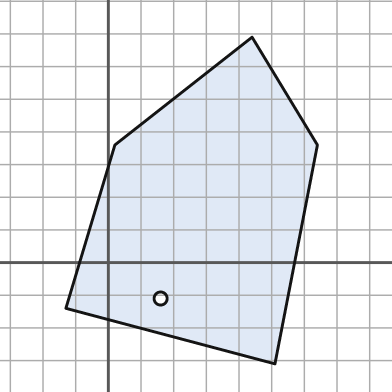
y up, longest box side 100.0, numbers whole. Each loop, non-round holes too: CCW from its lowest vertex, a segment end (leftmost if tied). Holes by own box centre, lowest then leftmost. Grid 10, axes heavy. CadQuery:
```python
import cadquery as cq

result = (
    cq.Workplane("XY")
    .moveTo(51.0, -31.0)
    .lineTo(64.0, 36.0)
    .lineTo(44.0, 69.0)
    .lineTo(2.0, 36.0)
    .lineTo(-13.0, -14.0)
    .close()
    .moveTo(16.0, -11.0)
    .circle(2.0)
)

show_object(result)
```